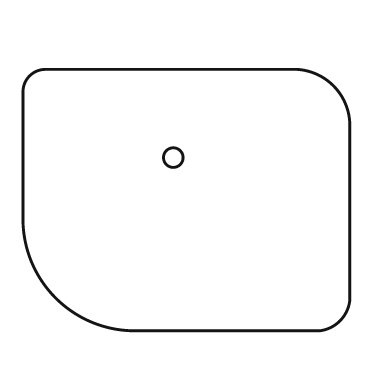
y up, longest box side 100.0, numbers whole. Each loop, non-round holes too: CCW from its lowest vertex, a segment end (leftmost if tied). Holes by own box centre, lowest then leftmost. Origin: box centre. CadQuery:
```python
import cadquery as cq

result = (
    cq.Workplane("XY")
    .moveTo(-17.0, -40.0)
    .lineTo(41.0, -40.0)
    .threePointArc((47.0, -37.0), (50.0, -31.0))
    .lineTo(50.0, 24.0)
    .threePointArc((45.0, 35.0), (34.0, 40.0))
    .lineTo(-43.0, 40.0)
    .threePointArc((-48.0, 38.0), (-50.0, 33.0))
    .lineTo(-50.0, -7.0)
    .threePointArc((-40.0, -30.0), (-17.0, -40.0))
    .close()
    .moveTo(-4.0, 13.0)
    .circle(3.0)
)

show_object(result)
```